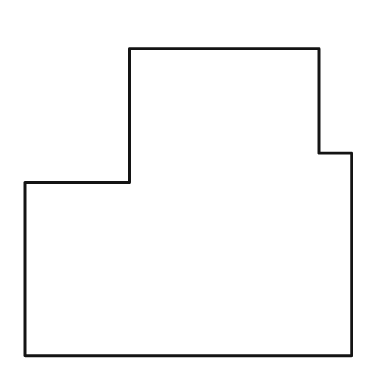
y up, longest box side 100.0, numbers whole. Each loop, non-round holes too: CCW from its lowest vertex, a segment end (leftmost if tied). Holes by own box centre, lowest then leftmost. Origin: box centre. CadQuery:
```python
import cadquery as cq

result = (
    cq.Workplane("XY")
    .moveTo(-50.0, -47.0)
    .lineTo(50.0, -47.0)
    .lineTo(50.0, 15.0)
    .lineTo(40.0, 15.0)
    .lineTo(40.0, 47.0)
    .lineTo(-18.0, 47.0)
    .lineTo(-18.0, 6.0)
    .lineTo(-50.0, 6.0)
    .close()
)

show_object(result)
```